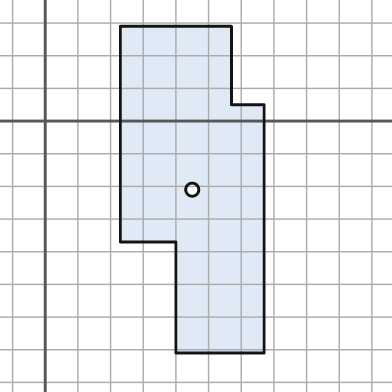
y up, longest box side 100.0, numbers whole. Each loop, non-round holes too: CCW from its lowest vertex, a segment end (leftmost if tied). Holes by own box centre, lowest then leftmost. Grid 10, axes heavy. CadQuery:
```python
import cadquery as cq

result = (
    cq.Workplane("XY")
    .moveTo(40.0, -71.0)
    .lineTo(67.0, -71.0)
    .lineTo(67.0, 5.0)
    .lineTo(57.0, 5.0)
    .lineTo(57.0, 29.0)
    .lineTo(23.0, 29.0)
    .lineTo(23.0, -37.0)
    .lineTo(40.0, -37.0)
    .close()
    .moveTo(45.0, -21.0)
    .circle(2.0)
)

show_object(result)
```